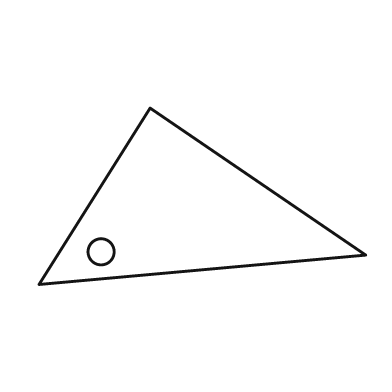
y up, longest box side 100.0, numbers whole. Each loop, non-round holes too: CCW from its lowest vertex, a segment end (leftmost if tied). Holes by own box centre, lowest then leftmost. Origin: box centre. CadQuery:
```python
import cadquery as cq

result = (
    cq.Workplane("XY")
    .moveTo(-50.0, -27.0)
    .lineTo(50.0, -18.0)
    .lineTo(-16.0, 27.0)
    .close()
    .moveTo(-31.0, -17.0)
    .circle(4.0)
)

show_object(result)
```